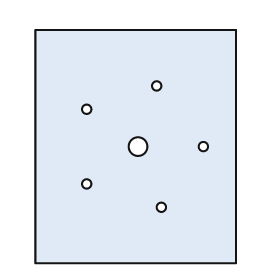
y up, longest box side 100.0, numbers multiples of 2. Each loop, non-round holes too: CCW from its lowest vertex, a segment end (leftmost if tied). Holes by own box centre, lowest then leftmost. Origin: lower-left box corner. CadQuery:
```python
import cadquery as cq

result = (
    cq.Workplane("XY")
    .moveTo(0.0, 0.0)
    .lineTo(86.0, 0.0)
    .lineTo(86.0, 100.0)
    .lineTo(0.0, 100.0)
    .close()
    .moveTo(54.0, 24.0)
    .circle(2.0)
    .moveTo(22.0, 34.0)
    .circle(2.0)
    .moveTo(44.0, 50.0)
    .circle(4.0)
    .moveTo(72.0, 50.0)
    .circle(2.0)
    .moveTo(22.0, 66.0)
    .circle(2.0)
    .moveTo(52.0, 76.0)
    .circle(2.0)
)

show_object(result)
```